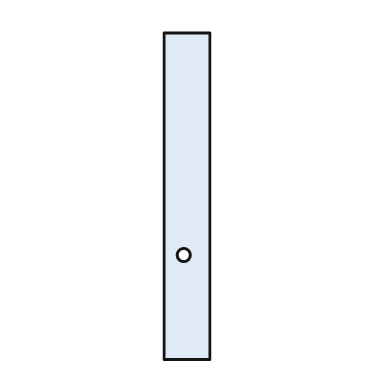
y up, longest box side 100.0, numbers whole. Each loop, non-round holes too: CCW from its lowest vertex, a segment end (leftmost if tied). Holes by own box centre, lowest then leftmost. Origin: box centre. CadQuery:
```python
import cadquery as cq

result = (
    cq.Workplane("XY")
    .moveTo(-7.0, -50.0)
    .lineTo(7.0, -50.0)
    .lineTo(7.0, 50.0)
    .lineTo(-7.0, 50.0)
    .close()
    .moveTo(-1.0, -18.0)
    .circle(2.0)
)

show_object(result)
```